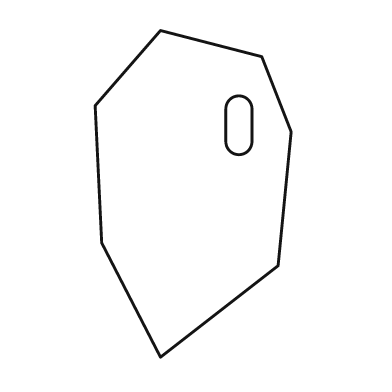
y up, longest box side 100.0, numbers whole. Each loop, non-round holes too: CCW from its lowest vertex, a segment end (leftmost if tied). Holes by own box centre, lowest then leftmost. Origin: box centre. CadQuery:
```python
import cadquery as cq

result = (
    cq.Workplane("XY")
    .moveTo(-10.0, -50.0)
    .lineTo(26.0, -22.0)
    .lineTo(30.0, 19.0)
    .lineTo(21.0, 42.0)
    .lineTo(-10.0, 50.0)
    .lineTo(-30.0, 27.0)
    .lineTo(-28.0, -15.0)
    .close()
    .moveTo(10.0, 16.0)
    .threePointArc((14.0, 12.0), (18.0, 16.0))
    .lineTo(18.0, 26.0)
    .threePointArc((14.0, 30.0), (10.0, 26.0))
    .close()
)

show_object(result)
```